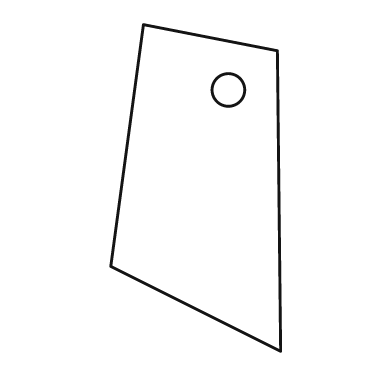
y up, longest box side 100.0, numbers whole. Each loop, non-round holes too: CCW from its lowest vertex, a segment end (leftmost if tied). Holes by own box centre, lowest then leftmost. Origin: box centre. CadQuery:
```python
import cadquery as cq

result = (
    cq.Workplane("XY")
    .moveTo(26.0, -50.0)
    .lineTo(25.0, 42.0)
    .lineTo(-16.0, 50.0)
    .lineTo(-26.0, -24.0)
    .close()
    .moveTo(10.0, 30.0)
    .circle(5.0)
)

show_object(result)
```